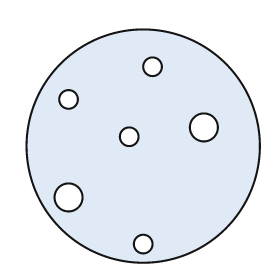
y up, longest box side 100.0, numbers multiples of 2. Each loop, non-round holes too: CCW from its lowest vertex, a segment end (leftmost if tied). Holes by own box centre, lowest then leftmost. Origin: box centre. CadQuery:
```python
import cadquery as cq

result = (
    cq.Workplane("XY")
    .moveTo(0.0, 0.0)
    .circle(50.0)
    .moveTo(0.0, -42.0)
    .circle(4.0)
    .moveTo(-32.0, -22.0)
    .circle(6.0)
    .moveTo(-6.0, 4.0)
    .circle(4.0)
    .moveTo(26.0, 8.0)
    .circle(6.0)
    .moveTo(-32.0, 20.0)
    .circle(4.0)
    .moveTo(4.0, 34.0)
    .circle(4.0)
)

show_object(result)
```